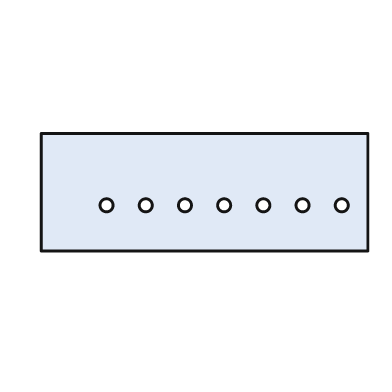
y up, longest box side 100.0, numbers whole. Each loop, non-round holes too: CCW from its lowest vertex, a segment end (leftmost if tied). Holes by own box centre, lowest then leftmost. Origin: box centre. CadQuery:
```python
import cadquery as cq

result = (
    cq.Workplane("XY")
    .moveTo(-50.0, -18.0)
    .lineTo(50.0, -18.0)
    .lineTo(50.0, 18.0)
    .lineTo(-50.0, 18.0)
    .close()
    .moveTo(-30.0, -4.0)
    .circle(2.0)
    .moveTo(-18.0, -4.0)
    .circle(2.0)
    .moveTo(-6.0, -4.0)
    .circle(2.0)
    .moveTo(6.0, -4.0)
    .circle(2.0)
    .moveTo(18.0, -4.0)
    .circle(2.0)
    .moveTo(30.0, -4.0)
    .circle(2.0)
    .moveTo(42.0, -4.0)
    .circle(2.0)
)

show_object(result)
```